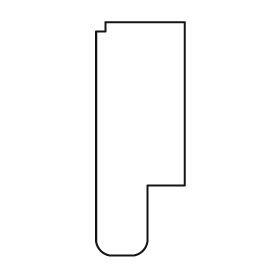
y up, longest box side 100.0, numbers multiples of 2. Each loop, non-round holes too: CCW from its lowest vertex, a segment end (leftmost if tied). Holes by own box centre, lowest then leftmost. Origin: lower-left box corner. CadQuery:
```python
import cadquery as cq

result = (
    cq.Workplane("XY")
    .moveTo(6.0, 0.0)
    .lineTo(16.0, 0.0)
    .threePointArc((20.0, 2.0), (22.0, 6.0))
    .lineTo(22.0, 30.0)
    .lineTo(38.0, 30.0)
    .lineTo(38.0, 100.0)
    .lineTo(4.0, 100.0)
    .lineTo(4.0, 96.0)
    .lineTo(0.0, 96.0)
    .lineTo(0.0, 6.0)
    .threePointArc((2.0, 2.0), (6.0, 0.0))
    .close()
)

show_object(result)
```